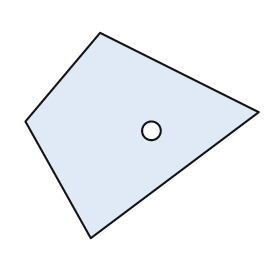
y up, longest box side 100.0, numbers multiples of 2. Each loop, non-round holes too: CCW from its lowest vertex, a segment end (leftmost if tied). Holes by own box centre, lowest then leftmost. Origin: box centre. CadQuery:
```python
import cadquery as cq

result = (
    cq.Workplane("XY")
    .moveTo(-22.0, -44.0)
    .lineTo(50.0, 10.0)
    .lineTo(-18.0, 44.0)
    .lineTo(-50.0, 6.0)
    .close()
    .moveTo(4.0, 2.0)
    .circle(4.0)
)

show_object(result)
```